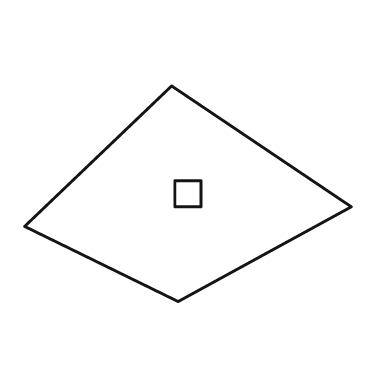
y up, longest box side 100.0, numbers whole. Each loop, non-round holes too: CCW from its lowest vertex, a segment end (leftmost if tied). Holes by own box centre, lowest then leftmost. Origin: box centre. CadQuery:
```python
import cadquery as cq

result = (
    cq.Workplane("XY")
    .moveTo(-3.0, -33.0)
    .lineTo(50.0, -4.0)
    .lineTo(-5.0, 33.0)
    .lineTo(-50.0, -10.0)
    .close()
    .moveTo(-4.0, -4.0)
    .lineTo(4.0, -4.0)
    .lineTo(4.0, 4.0)
    .lineTo(-4.0, 4.0)
    .close()
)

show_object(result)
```